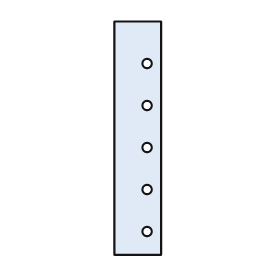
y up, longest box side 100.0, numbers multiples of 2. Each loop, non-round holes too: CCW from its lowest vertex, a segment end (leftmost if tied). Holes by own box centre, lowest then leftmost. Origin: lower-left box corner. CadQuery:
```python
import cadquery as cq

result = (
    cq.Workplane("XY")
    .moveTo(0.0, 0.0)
    .lineTo(20.0, 0.0)
    .lineTo(20.0, 100.0)
    .lineTo(0.0, 100.0)
    .close()
    .moveTo(14.0, 10.0)
    .circle(2.0)
    .moveTo(14.0, 28.0)
    .circle(2.0)
    .moveTo(14.0, 46.0)
    .circle(2.0)
    .moveTo(14.0, 64.0)
    .circle(2.0)
    .moveTo(14.0, 82.0)
    .circle(2.0)
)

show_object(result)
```